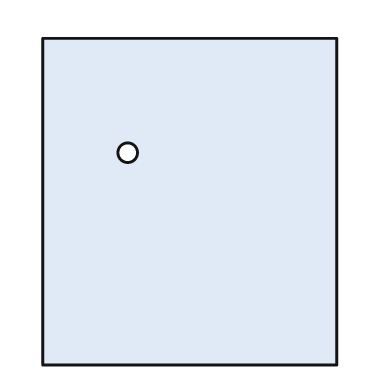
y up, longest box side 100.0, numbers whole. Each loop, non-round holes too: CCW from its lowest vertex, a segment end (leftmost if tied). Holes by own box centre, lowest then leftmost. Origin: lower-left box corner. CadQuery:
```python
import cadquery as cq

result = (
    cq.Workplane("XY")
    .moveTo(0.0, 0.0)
    .lineTo(90.0, 0.0)
    .lineTo(90.0, 100.0)
    .lineTo(0.0, 100.0)
    .close()
    .moveTo(26.0, 65.0)
    .circle(3.0)
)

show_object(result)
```